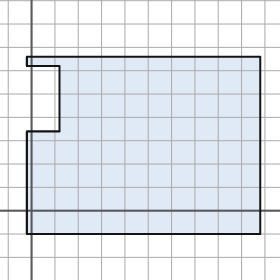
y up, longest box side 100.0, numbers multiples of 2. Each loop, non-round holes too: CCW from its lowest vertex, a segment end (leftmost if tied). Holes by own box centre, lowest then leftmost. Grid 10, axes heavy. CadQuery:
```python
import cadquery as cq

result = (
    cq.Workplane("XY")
    .moveTo(-2.0, -10.0)
    .lineTo(98.0, -10.0)
    .lineTo(98.0, 66.0)
    .lineTo(-2.0, 66.0)
    .lineTo(-2.0, 62.0)
    .lineTo(12.0, 62.0)
    .lineTo(12.0, 34.0)
    .lineTo(-2.0, 34.0)
    .close()
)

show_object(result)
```